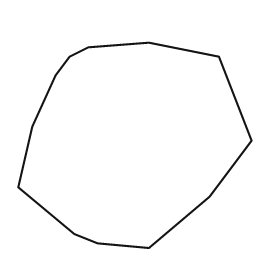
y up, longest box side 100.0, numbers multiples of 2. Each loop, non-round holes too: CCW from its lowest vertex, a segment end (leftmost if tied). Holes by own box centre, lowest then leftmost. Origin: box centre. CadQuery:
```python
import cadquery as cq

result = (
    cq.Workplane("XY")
    .moveTo(6.0, -44.0)
    .lineTo(32.0, -22.0)
    .lineTo(50.0, 2.0)
    .lineTo(36.0, 38.0)
    .lineTo(6.0, 44.0)
    .lineTo(-20.0, 42.0)
    .lineTo(-28.0, 38.0)
    .lineTo(-34.0, 30.0)
    .lineTo(-44.0, 8.0)
    .lineTo(-50.0, -18.0)
    .lineTo(-26.0, -38.0)
    .lineTo(-16.0, -42.0)
    .close()
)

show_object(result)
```